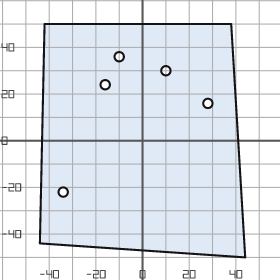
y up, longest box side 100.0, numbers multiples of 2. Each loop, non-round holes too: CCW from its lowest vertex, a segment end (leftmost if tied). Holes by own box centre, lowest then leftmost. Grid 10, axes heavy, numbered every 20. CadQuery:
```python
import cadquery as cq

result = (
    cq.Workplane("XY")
    .moveTo(44.0, -50.0)
    .lineTo(38.0, 50.0)
    .lineTo(-42.0, 50.0)
    .lineTo(-44.0, -44.0)
    .close()
    .moveTo(-34.0, -22.0)
    .circle(2.0)
    .moveTo(28.0, 16.0)
    .circle(2.0)
    .moveTo(-16.0, 24.0)
    .circle(2.0)
    .moveTo(10.0, 30.0)
    .circle(2.0)
    .moveTo(-10.0, 36.0)
    .circle(2.0)
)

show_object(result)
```